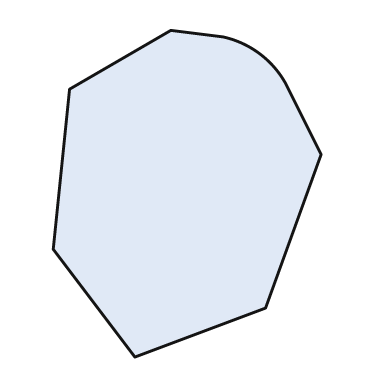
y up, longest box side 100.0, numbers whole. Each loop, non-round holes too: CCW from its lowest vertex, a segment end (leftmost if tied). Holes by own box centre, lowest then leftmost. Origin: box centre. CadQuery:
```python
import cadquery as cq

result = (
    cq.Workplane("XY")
    .moveTo(-16.0, -50.0)
    .lineTo(24.0, -35.0)
    .lineTo(41.0, 12.0)
    .lineTo(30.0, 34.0)
    .threePointArc((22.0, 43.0), (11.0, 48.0))
    .lineTo(-5.0, 50.0)
    .lineTo(-36.0, 32.0)
    .lineTo(-41.0, -17.0)
    .close()
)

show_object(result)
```